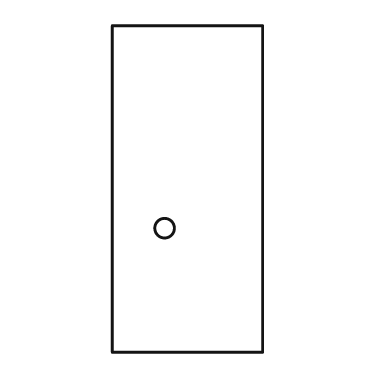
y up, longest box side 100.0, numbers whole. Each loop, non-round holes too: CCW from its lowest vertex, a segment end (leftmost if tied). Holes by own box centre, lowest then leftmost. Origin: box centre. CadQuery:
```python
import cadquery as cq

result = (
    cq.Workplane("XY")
    .moveTo(-23.0, -50.0)
    .lineTo(23.0, -50.0)
    .lineTo(23.0, 50.0)
    .lineTo(-23.0, 50.0)
    .close()
    .moveTo(-7.0, -12.0)
    .circle(3.0)
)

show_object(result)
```